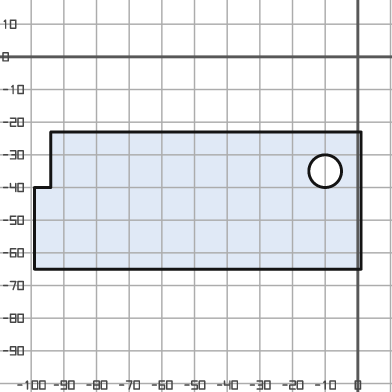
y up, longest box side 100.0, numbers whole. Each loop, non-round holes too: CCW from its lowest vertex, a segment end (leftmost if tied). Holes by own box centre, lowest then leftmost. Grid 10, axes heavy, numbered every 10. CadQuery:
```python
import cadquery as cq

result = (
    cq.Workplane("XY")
    .moveTo(-99.0, -65.0)
    .lineTo(1.0, -65.0)
    .lineTo(1.0, -23.0)
    .lineTo(-94.0, -23.0)
    .lineTo(-94.0, -40.0)
    .lineTo(-99.0, -40.0)
    .close()
    .moveTo(-10.0, -35.0)
    .circle(5.0)
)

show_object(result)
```